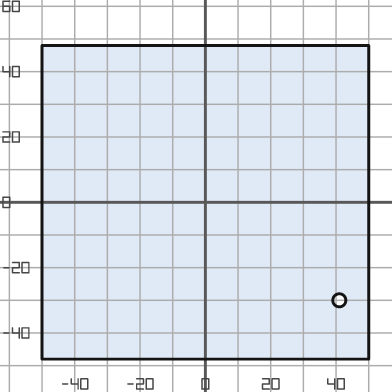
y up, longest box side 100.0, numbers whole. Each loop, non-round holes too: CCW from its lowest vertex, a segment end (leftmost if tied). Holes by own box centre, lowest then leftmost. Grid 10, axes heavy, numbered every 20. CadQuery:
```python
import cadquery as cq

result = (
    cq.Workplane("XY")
    .moveTo(-50.0, -48.0)
    .lineTo(50.0, -48.0)
    .lineTo(50.0, 48.0)
    .lineTo(-50.0, 48.0)
    .close()
    .moveTo(41.0, -30.0)
    .circle(2.0)
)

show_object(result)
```